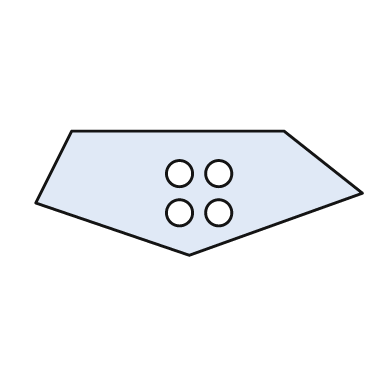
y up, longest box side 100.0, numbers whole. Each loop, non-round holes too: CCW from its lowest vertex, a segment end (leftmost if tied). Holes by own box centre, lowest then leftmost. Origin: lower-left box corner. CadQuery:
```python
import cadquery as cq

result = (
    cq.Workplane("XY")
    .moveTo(47.0, 0.0)
    .lineTo(100.0, 19.0)
    .lineTo(76.0, 38.0)
    .lineTo(11.0, 38.0)
    .lineTo(0.0, 16.0)
    .close()
    .moveTo(44.0, 13.0)
    .circle(4.0)
    .moveTo(56.0, 13.0)
    .circle(4.0)
    .moveTo(44.0, 25.0)
    .circle(4.0)
    .moveTo(56.0, 25.0)
    .circle(4.0)
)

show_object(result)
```